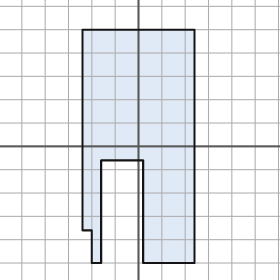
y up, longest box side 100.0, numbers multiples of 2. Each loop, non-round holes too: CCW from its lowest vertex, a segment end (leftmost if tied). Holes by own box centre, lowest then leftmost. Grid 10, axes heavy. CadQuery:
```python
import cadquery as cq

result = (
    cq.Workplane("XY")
    .moveTo(-20.0, -50.0)
    .lineTo(-16.0, -50.0)
    .lineTo(-16.0, -6.0)
    .lineTo(2.0, -6.0)
    .lineTo(2.0, -50.0)
    .lineTo(24.0, -50.0)
    .lineTo(24.0, 50.0)
    .lineTo(-24.0, 50.0)
    .lineTo(-24.0, -36.0)
    .lineTo(-20.0, -36.0)
    .close()
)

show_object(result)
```